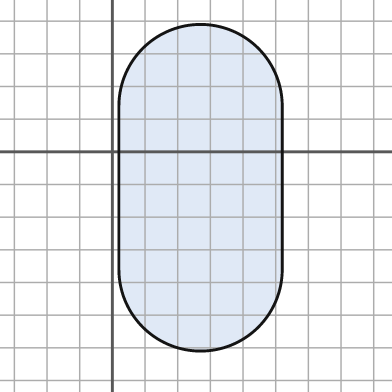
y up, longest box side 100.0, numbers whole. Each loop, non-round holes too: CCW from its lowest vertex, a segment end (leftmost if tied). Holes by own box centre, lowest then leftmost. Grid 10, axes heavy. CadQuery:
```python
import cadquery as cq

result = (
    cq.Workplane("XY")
    .moveTo(2.0, -36.0)
    .threePointArc((27.0, -61.0), (52.0, -36.0))
    .lineTo(52.0, 14.0)
    .threePointArc((27.0, 39.0), (2.0, 14.0))
    .close()
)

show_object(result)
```